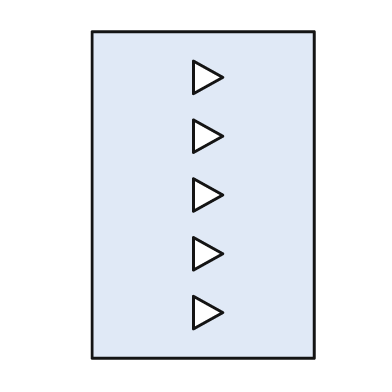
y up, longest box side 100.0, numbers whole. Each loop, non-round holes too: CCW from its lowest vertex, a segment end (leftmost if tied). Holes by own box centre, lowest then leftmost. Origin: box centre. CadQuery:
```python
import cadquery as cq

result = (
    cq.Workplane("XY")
    .moveTo(-34.0, -50.0)
    .lineTo(34.0, -50.0)
    .lineTo(34.0, 50.0)
    .lineTo(-34.0, 50.0)
    .close()
    .moveTo(-3.0, -41.0)
    .lineTo(6.0, -36.0)
    .lineTo(-3.0, -31.0)
    .close()
    .moveTo(-3.0, -23.0)
    .lineTo(6.0, -18.0)
    .lineTo(-3.0, -13.0)
    .close()
    .moveTo(-3.0, -5.0)
    .lineTo(6.0, 0.0)
    .lineTo(-3.0, 5.0)
    .close()
    .moveTo(-3.0, 13.0)
    .lineTo(6.0, 18.0)
    .lineTo(-3.0, 23.0)
    .close()
    .moveTo(-3.0, 31.0)
    .lineTo(6.0, 36.0)
    .lineTo(-3.0, 41.0)
    .close()
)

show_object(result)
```